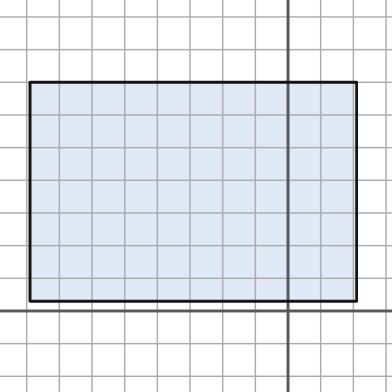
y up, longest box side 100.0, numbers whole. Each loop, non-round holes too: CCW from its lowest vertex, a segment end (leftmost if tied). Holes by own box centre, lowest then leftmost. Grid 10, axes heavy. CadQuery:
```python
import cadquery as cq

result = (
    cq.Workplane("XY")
    .moveTo(-79.0, 3.0)
    .lineTo(21.0, 3.0)
    .lineTo(21.0, 70.0)
    .lineTo(-79.0, 70.0)
    .close()
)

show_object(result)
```